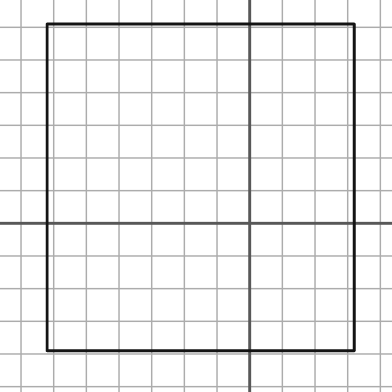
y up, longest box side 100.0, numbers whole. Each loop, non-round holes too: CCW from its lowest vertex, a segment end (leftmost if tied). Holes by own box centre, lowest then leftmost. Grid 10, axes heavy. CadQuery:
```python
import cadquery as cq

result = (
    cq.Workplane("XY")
    .moveTo(-62.0, -39.0)
    .lineTo(32.0, -39.0)
    .lineTo(32.0, 61.0)
    .lineTo(-62.0, 61.0)
    .close()
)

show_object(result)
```